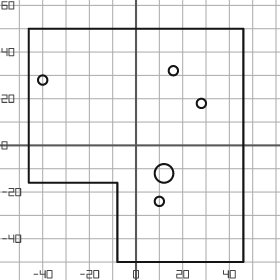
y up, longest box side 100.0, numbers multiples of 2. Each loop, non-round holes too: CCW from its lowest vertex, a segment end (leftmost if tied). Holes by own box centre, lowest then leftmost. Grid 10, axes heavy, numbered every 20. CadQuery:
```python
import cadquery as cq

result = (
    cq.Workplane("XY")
    .moveTo(-8.0, -50.0)
    .lineTo(46.0, -50.0)
    .lineTo(46.0, 50.0)
    .lineTo(-46.0, 50.0)
    .lineTo(-46.0, -16.0)
    .lineTo(-8.0, -16.0)
    .close()
    .moveTo(10.0, -24.0)
    .circle(2.0)
    .moveTo(12.0, -12.0)
    .circle(4.0)
    .moveTo(28.0, 18.0)
    .circle(2.0)
    .moveTo(-40.0, 28.0)
    .circle(2.0)
    .moveTo(16.0, 32.0)
    .circle(2.0)
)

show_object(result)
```